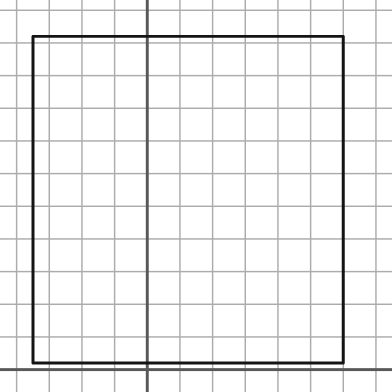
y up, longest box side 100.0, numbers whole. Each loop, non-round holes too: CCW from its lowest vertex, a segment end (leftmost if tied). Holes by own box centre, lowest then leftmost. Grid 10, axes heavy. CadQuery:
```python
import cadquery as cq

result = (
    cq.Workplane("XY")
    .moveTo(-35.0, 2.0)
    .lineTo(60.0, 2.0)
    .lineTo(60.0, 102.0)
    .lineTo(-35.0, 102.0)
    .close()
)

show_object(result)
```